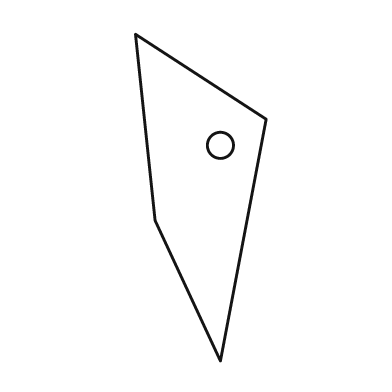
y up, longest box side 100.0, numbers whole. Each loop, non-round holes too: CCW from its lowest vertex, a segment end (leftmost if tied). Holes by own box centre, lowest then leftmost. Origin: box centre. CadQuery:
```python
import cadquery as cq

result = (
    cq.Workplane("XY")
    .moveTo(6.0, -50.0)
    .lineTo(20.0, 24.0)
    .lineTo(-20.0, 50.0)
    .lineTo(-14.0, -7.0)
    .close()
    .moveTo(6.0, 16.0)
    .circle(4.0)
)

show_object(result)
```